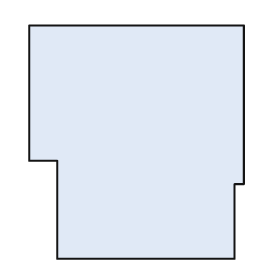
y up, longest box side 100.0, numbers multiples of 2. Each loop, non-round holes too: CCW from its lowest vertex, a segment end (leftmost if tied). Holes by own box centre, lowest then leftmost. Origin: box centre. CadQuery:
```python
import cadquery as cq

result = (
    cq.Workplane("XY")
    .moveTo(-34.0, -50.0)
    .lineTo(42.0, -50.0)
    .lineTo(42.0, -18.0)
    .lineTo(46.0, -18.0)
    .lineTo(46.0, 50.0)
    .lineTo(-46.0, 50.0)
    .lineTo(-46.0, -8.0)
    .lineTo(-34.0, -8.0)
    .close()
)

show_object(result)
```